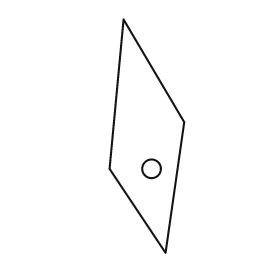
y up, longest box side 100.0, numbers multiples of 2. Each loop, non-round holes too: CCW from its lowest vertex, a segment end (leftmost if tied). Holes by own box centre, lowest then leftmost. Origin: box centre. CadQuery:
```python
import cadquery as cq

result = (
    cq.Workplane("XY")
    .moveTo(8.0, -50.0)
    .lineTo(16.0, 6.0)
    .lineTo(-10.0, 50.0)
    .lineTo(-16.0, -14.0)
    .close()
    .moveTo(2.0, -14.0)
    .circle(4.0)
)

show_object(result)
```